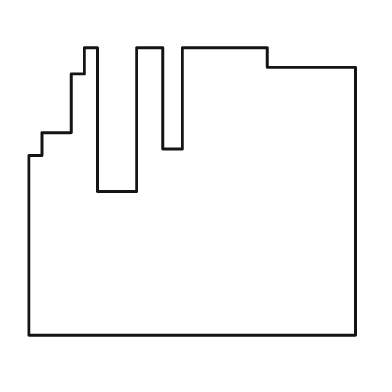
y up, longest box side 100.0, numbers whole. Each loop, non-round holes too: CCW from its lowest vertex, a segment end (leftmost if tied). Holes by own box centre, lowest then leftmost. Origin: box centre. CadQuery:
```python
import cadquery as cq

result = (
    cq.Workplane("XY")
    .moveTo(-50.0, -44.0)
    .lineTo(50.0, -44.0)
    .lineTo(50.0, 38.0)
    .lineTo(23.0, 38.0)
    .lineTo(23.0, 44.0)
    .lineTo(-3.0, 44.0)
    .lineTo(-3.0, 13.0)
    .lineTo(-9.0, 13.0)
    .lineTo(-9.0, 44.0)
    .lineTo(-17.0, 44.0)
    .lineTo(-17.0, 0.0)
    .lineTo(-29.0, 0.0)
    .lineTo(-29.0, 44.0)
    .lineTo(-33.0, 44.0)
    .lineTo(-33.0, 36.0)
    .lineTo(-37.0, 36.0)
    .lineTo(-37.0, 18.0)
    .lineTo(-46.0, 18.0)
    .lineTo(-46.0, 11.0)
    .lineTo(-50.0, 11.0)
    .close()
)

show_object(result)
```